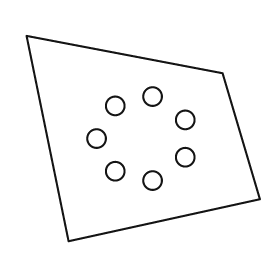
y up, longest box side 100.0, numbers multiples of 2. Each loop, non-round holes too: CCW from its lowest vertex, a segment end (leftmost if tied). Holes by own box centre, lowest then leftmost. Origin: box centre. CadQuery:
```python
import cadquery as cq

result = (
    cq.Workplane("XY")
    .moveTo(-32.0, -44.0)
    .lineTo(50.0, -26.0)
    .lineTo(34.0, 28.0)
    .lineTo(-50.0, 44.0)
    .close()
    .moveTo(4.0, -18.0)
    .circle(4.0)
    .moveTo(-12.0, -14.0)
    .circle(4.0)
    .moveTo(18.0, -8.0)
    .circle(4.0)
    .moveTo(-20.0, 0.0)
    .circle(4.0)
    .moveTo(18.0, 8.0)
    .circle(4.0)
    .moveTo(-12.0, 14.0)
    .circle(4.0)
    .moveTo(4.0, 18.0)
    .circle(4.0)
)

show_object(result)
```